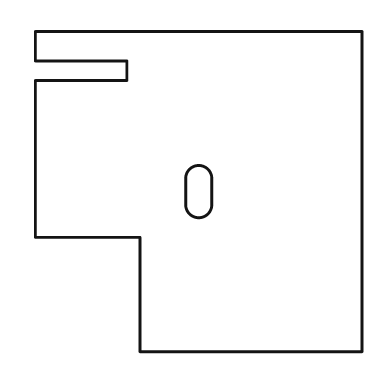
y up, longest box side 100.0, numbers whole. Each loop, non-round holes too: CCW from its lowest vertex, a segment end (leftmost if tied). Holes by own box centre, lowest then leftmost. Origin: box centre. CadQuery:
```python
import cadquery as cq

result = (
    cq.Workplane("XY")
    .moveTo(-18.0, -49.0)
    .lineTo(50.0, -49.0)
    .lineTo(50.0, 49.0)
    .lineTo(-50.0, 49.0)
    .lineTo(-50.0, 40.0)
    .lineTo(-22.0, 40.0)
    .lineTo(-22.0, 34.0)
    .lineTo(-50.0, 34.0)
    .lineTo(-50.0, -14.0)
    .lineTo(-18.0, -14.0)
    .close()
    .moveTo(-4.0, -4.0)
    .threePointArc((0.0, -8.0), (4.0, -4.0))
    .lineTo(4.0, 4.0)
    .threePointArc((0.0, 8.0), (-4.0, 4.0))
    .close()
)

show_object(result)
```